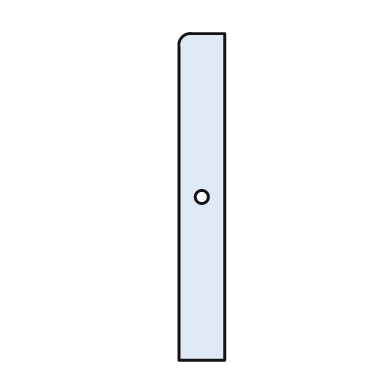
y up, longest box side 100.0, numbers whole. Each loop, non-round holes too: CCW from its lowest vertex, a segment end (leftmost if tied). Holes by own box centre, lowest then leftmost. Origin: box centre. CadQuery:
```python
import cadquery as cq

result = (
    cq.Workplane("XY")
    .moveTo(-7.0, -50.0)
    .lineTo(7.0, -50.0)
    .lineTo(7.0, 50.0)
    .lineTo(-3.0, 50.0)
    .threePointArc((-6.0, 49.0), (-7.0, 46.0))
    .close()
    .moveTo(0.0, 0.0)
    .circle(2.0)
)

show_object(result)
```